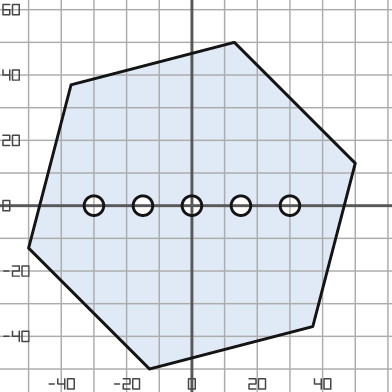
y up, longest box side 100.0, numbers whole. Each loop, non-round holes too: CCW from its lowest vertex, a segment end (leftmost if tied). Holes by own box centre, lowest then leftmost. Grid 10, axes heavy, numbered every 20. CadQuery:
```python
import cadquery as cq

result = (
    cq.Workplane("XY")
    .moveTo(-13.0, -50.0)
    .lineTo(37.0, -37.0)
    .lineTo(50.0, 13.0)
    .lineTo(13.0, 50.0)
    .lineTo(-37.0, 37.0)
    .lineTo(-50.0, -13.0)
    .close()
    .moveTo(-30.0, 0.0)
    .circle(3.0)
    .moveTo(-15.0, 0.0)
    .circle(3.0)
    .moveTo(0.0, 0.0)
    .circle(3.0)
    .moveTo(15.0, 0.0)
    .circle(3.0)
    .moveTo(30.0, 0.0)
    .circle(3.0)
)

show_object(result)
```